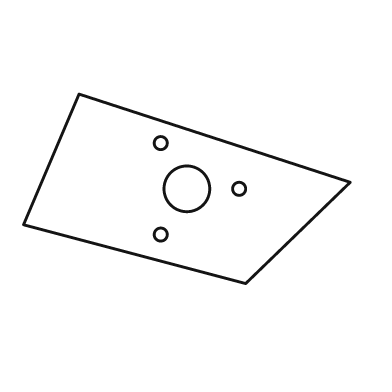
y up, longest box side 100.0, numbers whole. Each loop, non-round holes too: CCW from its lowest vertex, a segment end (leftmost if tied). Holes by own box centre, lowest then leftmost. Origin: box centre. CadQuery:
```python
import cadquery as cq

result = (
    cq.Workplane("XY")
    .moveTo(18.0, -29.0)
    .lineTo(50.0, 2.0)
    .lineTo(-33.0, 29.0)
    .lineTo(-50.0, -11.0)
    .close()
    .moveTo(-8.0, -14.0)
    .circle(2.0)
    .moveTo(0.0, 0.0)
    .circle(7.0)
    .moveTo(16.0, 0.0)
    .circle(2.0)
    .moveTo(-8.0, 14.0)
    .circle(2.0)
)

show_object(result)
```